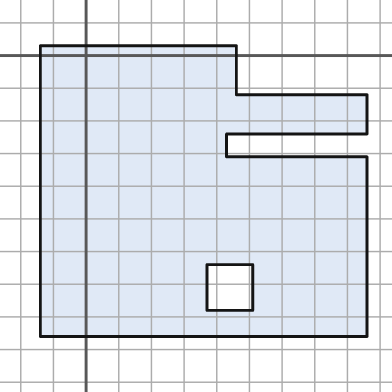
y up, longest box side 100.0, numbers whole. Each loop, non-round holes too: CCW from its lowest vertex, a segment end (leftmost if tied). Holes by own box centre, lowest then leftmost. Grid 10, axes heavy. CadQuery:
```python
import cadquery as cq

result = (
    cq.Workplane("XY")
    .moveTo(-14.0, -86.0)
    .lineTo(86.0, -86.0)
    .lineTo(86.0, -31.0)
    .lineTo(43.0, -31.0)
    .lineTo(43.0, -24.0)
    .lineTo(86.0, -24.0)
    .lineTo(86.0, -12.0)
    .lineTo(46.0, -12.0)
    .lineTo(46.0, 3.0)
    .lineTo(-14.0, 3.0)
    .close()
    .moveTo(37.0, -78.0)
    .lineTo(51.0, -78.0)
    .lineTo(51.0, -64.0)
    .lineTo(37.0, -64.0)
    .close()
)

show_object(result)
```